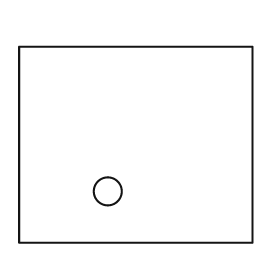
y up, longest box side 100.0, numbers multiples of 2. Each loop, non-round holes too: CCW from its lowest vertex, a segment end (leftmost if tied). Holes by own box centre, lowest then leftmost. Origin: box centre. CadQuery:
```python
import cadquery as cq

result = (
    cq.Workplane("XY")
    .moveTo(-50.0, -42.0)
    .lineTo(50.0, -42.0)
    .lineTo(50.0, 42.0)
    .lineTo(-50.0, 42.0)
    .close()
    .moveTo(-12.0, -20.0)
    .circle(6.0)
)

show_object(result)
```